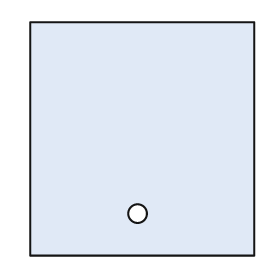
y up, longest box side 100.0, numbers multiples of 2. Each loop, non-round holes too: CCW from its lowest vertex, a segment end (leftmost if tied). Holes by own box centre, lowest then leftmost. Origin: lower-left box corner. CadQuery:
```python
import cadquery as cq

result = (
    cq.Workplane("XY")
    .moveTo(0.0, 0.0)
    .lineTo(96.0, 0.0)
    .lineTo(96.0, 100.0)
    .lineTo(0.0, 100.0)
    .close()
    .moveTo(46.0, 18.0)
    .circle(4.0)
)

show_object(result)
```